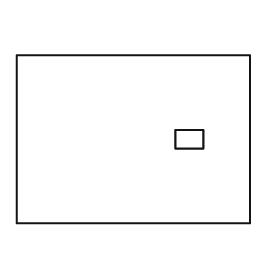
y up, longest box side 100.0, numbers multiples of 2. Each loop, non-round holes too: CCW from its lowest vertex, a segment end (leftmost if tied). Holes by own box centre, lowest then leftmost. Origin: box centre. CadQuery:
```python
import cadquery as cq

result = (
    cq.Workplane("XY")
    .moveTo(-50.0, -36.0)
    .lineTo(50.0, -36.0)
    .lineTo(50.0, 36.0)
    .lineTo(-50.0, 36.0)
    .close()
    .moveTo(18.0, -4.0)
    .lineTo(30.0, -4.0)
    .lineTo(30.0, 4.0)
    .lineTo(18.0, 4.0)
    .close()
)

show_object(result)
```